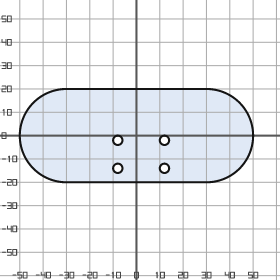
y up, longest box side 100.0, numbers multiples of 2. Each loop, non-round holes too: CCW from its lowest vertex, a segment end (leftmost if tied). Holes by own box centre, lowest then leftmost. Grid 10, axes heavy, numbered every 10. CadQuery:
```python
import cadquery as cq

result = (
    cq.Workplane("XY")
    .moveTo(-30.0, -20.0)
    .lineTo(30.0, -20.0)
    .threePointArc((50.0, 0.0), (30.0, 20.0))
    .lineTo(-30.0, 20.0)
    .threePointArc((-50.0, 0.0), (-30.0, -20.0))
    .close()
    .moveTo(-8.0, -14.0)
    .circle(2.0)
    .moveTo(12.0, -14.0)
    .circle(2.0)
    .moveTo(-8.0, -2.0)
    .circle(2.0)
    .moveTo(12.0, -2.0)
    .circle(2.0)
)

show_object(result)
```